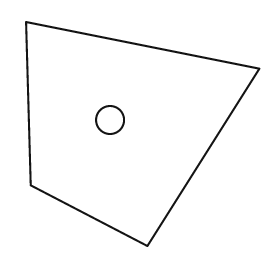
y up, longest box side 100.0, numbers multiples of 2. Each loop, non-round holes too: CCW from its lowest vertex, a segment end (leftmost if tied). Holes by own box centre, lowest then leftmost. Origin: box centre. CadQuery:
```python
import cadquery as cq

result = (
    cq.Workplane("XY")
    .moveTo(2.0, -48.0)
    .lineTo(50.0, 28.0)
    .lineTo(-50.0, 48.0)
    .lineTo(-48.0, -22.0)
    .close()
    .moveTo(-14.0, 6.0)
    .circle(6.0)
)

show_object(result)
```